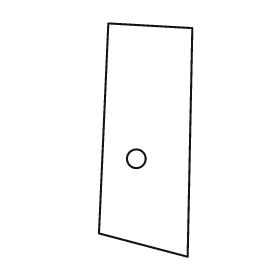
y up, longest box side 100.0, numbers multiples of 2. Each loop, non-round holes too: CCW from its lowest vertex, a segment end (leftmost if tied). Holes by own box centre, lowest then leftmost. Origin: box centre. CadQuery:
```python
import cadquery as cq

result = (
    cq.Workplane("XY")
    .moveTo(18.0, -50.0)
    .lineTo(20.0, 48.0)
    .lineTo(-16.0, 50.0)
    .lineTo(-20.0, -40.0)
    .close()
    .moveTo(-4.0, -8.0)
    .circle(4.0)
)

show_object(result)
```